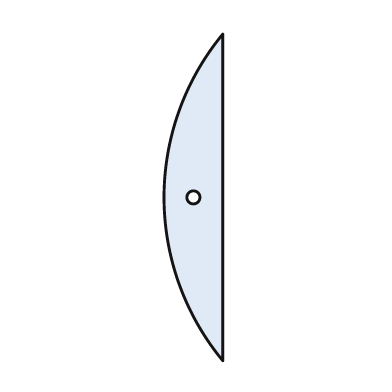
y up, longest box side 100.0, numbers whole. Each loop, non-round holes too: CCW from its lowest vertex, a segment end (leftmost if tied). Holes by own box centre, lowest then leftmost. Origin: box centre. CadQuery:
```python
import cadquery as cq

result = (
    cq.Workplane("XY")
    .moveTo(9.0, -50.0)
    .lineTo(9.0, 50.0)
    .threePointArc((-9.0, 0.0), (9.0, -50.0))
    .close()
    .moveTo(0.0, 0.0)
    .circle(2.0)
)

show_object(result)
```